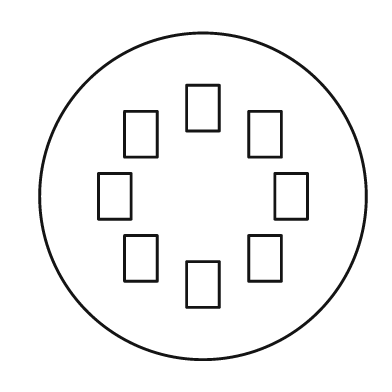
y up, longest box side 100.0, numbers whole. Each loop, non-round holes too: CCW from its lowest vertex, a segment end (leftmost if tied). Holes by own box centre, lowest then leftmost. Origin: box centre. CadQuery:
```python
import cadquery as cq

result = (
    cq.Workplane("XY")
    .moveTo(0.0, 0.0)
    .circle(50.0)
    .moveTo(-5.0, -34.0)
    .lineTo(5.0, -34.0)
    .lineTo(5.0, -20.0)
    .lineTo(-5.0, -20.0)
    .close()
    .moveTo(-24.0, -26.0)
    .lineTo(-14.0, -26.0)
    .lineTo(-14.0, -12.0)
    .lineTo(-24.0, -12.0)
    .close()
    .moveTo(14.0, -26.0)
    .lineTo(24.0, -26.0)
    .lineTo(24.0, -12.0)
    .lineTo(14.0, -12.0)
    .close()
    .moveTo(-32.0, -7.0)
    .lineTo(-22.0, -7.0)
    .lineTo(-22.0, 7.0)
    .lineTo(-32.0, 7.0)
    .close()
    .moveTo(22.0, -7.0)
    .lineTo(32.0, -7.0)
    .lineTo(32.0, 7.0)
    .lineTo(22.0, 7.0)
    .close()
    .moveTo(-24.0, 12.0)
    .lineTo(-14.0, 12.0)
    .lineTo(-14.0, 26.0)
    .lineTo(-24.0, 26.0)
    .close()
    .moveTo(14.0, 12.0)
    .lineTo(24.0, 12.0)
    .lineTo(24.0, 26.0)
    .lineTo(14.0, 26.0)
    .close()
    .moveTo(-5.0, 20.0)
    .lineTo(5.0, 20.0)
    .lineTo(5.0, 34.0)
    .lineTo(-5.0, 34.0)
    .close()
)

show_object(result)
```